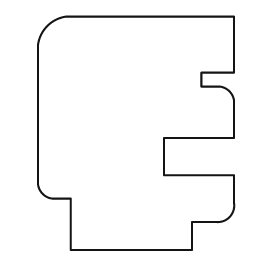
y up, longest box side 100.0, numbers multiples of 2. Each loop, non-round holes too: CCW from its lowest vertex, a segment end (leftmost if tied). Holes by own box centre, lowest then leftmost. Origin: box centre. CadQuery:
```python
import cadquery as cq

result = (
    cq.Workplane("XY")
    .moveTo(-28.0, -50.0)
    .lineTo(24.0, -50.0)
    .lineTo(24.0, -38.0)
    .lineTo(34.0, -38.0)
    .threePointArc((40.0, -36.0), (42.0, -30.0))
    .lineTo(42.0, -18.0)
    .lineTo(12.0, -18.0)
    .lineTo(12.0, -2.0)
    .lineTo(42.0, -2.0)
    .lineTo(42.0, 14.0)
    .threePointArc((40.0, 18.0), (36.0, 20.0))
    .lineTo(28.0, 20.0)
    .lineTo(28.0, 26.0)
    .lineTo(42.0, 26.0)
    .lineTo(42.0, 50.0)
    .lineTo(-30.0, 50.0)
    .threePointArc((-38.0, 46.0), (-42.0, 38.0))
    .lineTo(-42.0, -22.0)
    .threePointArc((-40.0, -26.0), (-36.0, -28.0))
    .lineTo(-28.0, -28.0)
    .close()
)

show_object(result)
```